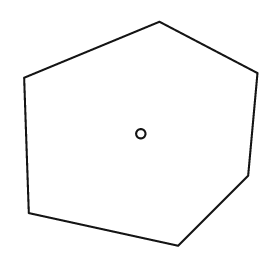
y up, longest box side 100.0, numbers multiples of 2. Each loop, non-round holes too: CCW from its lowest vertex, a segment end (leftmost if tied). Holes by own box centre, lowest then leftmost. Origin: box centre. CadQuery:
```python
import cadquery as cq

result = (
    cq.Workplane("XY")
    .moveTo(16.0, -48.0)
    .lineTo(46.0, -18.0)
    .lineTo(50.0, 26.0)
    .lineTo(8.0, 48.0)
    .lineTo(-50.0, 24.0)
    .lineTo(-48.0, -34.0)
    .close()
    .moveTo(0.0, 0.0)
    .circle(2.0)
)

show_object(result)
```